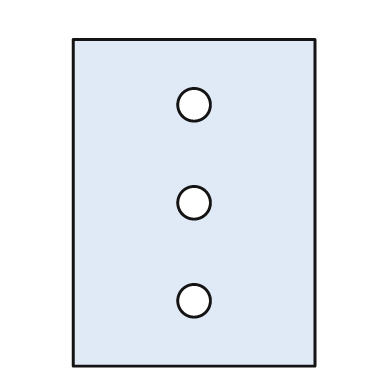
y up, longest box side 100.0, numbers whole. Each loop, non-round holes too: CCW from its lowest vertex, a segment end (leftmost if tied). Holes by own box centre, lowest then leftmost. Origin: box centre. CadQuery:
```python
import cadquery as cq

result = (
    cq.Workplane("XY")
    .moveTo(-37.0, -50.0)
    .lineTo(37.0, -50.0)
    .lineTo(37.0, 50.0)
    .lineTo(-37.0, 50.0)
    .close()
    .moveTo(0.0, -30.0)
    .circle(5.0)
    .moveTo(0.0, 0.0)
    .circle(5.0)
    .moveTo(0.0, 30.0)
    .circle(5.0)
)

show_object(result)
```